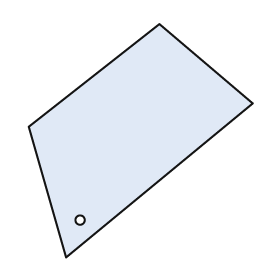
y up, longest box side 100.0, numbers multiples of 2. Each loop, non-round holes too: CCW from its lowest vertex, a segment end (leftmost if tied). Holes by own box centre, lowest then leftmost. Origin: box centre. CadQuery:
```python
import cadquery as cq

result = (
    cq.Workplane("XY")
    .moveTo(-32.0, -50.0)
    .lineTo(48.0, 16.0)
    .lineTo(8.0, 50.0)
    .lineTo(-48.0, 6.0)
    .close()
    .moveTo(-26.0, -34.0)
    .circle(2.0)
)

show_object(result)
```